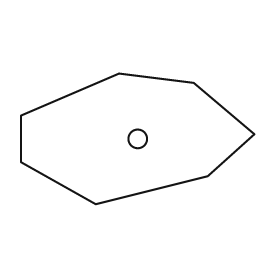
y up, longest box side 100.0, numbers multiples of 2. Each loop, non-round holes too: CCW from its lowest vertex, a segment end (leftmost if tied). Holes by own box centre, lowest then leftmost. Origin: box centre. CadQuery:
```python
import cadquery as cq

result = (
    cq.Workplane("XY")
    .moveTo(-18.0, -28.0)
    .lineTo(30.0, -16.0)
    .lineTo(50.0, 2.0)
    .lineTo(24.0, 24.0)
    .lineTo(-8.0, 28.0)
    .lineTo(-50.0, 10.0)
    .lineTo(-50.0, -10.0)
    .close()
    .moveTo(0.0, 0.0)
    .circle(4.0)
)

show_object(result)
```